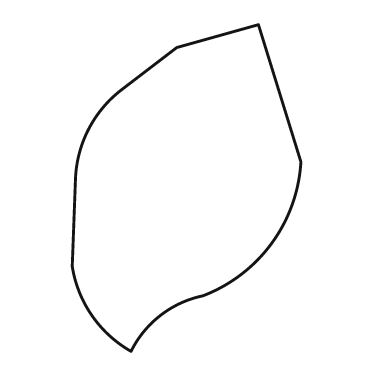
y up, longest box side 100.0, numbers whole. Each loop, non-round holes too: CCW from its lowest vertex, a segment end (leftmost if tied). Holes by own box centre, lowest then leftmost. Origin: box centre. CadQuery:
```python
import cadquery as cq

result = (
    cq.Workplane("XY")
    .moveTo(-17.0, -50.0)
    .threePointArc((-8.0, -39.0), (5.0, -33.0))
    .threePointArc((26.0, -17.0), (35.0, 8.0))
    .lineTo(22.0, 50.0)
    .lineTo(-3.0, 43.0)
    .lineTo(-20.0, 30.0)
    .threePointArc((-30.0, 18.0), (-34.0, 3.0))
    .lineTo(-35.0, -24.0)
    .threePointArc((-29.0, -39.0), (-17.0, -50.0))
    .close()
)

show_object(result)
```